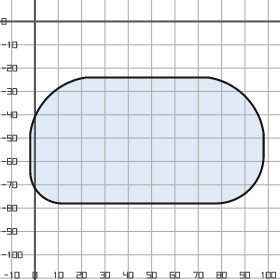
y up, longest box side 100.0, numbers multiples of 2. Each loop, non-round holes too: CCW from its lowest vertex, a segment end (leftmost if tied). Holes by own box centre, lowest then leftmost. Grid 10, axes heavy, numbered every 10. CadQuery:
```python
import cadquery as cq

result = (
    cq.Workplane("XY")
    .moveTo(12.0, -78.0)
    .lineTo(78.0, -78.0)
    .threePointArc((92.0, -72.0), (98.0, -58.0))
    .lineTo(98.0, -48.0)
    .threePointArc((90.0, -32.0), (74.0, -24.0))
    .lineTo(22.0, -24.0)
    .threePointArc((6.0, -32.0), (-2.0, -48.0))
    .lineTo(-2.0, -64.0)
    .threePointArc((2.0, -74.0), (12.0, -78.0))
    .close()
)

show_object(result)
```